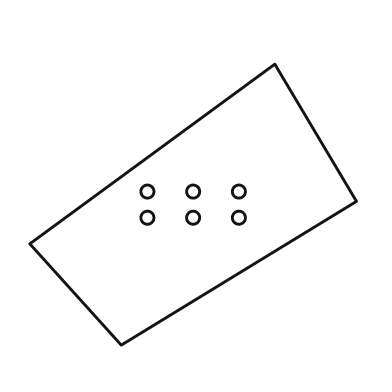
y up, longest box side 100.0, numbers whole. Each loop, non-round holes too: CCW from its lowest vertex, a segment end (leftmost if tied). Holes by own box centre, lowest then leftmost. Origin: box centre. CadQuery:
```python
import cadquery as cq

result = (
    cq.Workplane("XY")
    .moveTo(-22.0, -43.0)
    .lineTo(50.0, 1.0)
    .lineTo(25.0, 43.0)
    .lineTo(-50.0, -12.0)
    .close()
    .moveTo(-14.0, -4.0)
    .circle(2.0)
    .moveTo(0.0, -4.0)
    .circle(2.0)
    .moveTo(14.0, -4.0)
    .circle(2.0)
    .moveTo(-14.0, 4.0)
    .circle(2.0)
    .moveTo(0.0, 4.0)
    .circle(2.0)
    .moveTo(14.0, 4.0)
    .circle(2.0)
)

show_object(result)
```